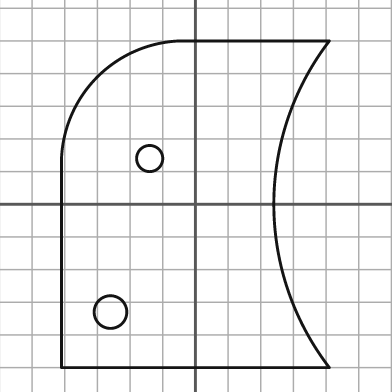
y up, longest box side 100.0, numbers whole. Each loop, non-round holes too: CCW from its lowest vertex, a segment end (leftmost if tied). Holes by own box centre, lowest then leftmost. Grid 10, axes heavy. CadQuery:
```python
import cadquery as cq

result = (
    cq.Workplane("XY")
    .moveTo(-41.0, -50.0)
    .lineTo(41.0, -50.0)
    .threePointArc((24.0, 0.0), (41.0, 50.0))
    .lineTo(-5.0, 50.0)
    .threePointArc((-30.0, 39.0), (-41.0, 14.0))
    .close()
    .moveTo(-26.0, -33.0)
    .circle(5.0)
    .moveTo(-14.0, 14.0)
    .circle(4.0)
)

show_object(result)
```